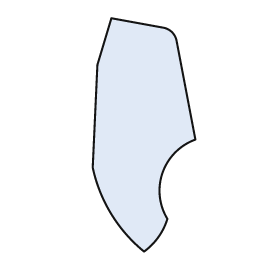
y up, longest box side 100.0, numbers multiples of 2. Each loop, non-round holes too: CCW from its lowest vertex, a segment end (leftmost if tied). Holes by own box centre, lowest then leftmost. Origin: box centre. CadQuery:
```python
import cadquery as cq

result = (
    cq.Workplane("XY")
    .moveTo(0.0, -50.0)
    .threePointArc((6.0, -44.0), (10.0, -36.0))
    .threePointArc((8.0, -16.0), (22.0, -2.0))
    .lineTo(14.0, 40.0)
    .threePointArc((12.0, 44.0), (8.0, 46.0))
    .lineTo(-14.0, 50.0)
    .lineTo(-20.0, 30.0)
    .lineTo(-22.0, -14.0)
    .threePointArc((-14.0, -34.0), (0.0, -50.0))
    .close()
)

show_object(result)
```